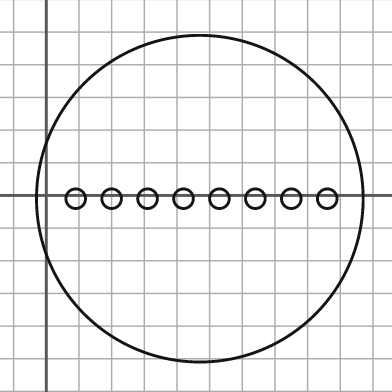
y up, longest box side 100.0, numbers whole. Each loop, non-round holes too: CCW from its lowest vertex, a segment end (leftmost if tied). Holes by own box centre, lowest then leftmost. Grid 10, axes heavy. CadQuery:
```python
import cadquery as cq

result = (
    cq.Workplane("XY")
    .moveTo(47.0, -1.0)
    .circle(50.0)
    .moveTo(9.0, -1.0)
    .circle(3.0)
    .moveTo(20.0, -1.0)
    .circle(3.0)
    .moveTo(31.0, -1.0)
    .circle(3.0)
    .moveTo(42.0, -1.0)
    .circle(3.0)
    .moveTo(53.0, -1.0)
    .circle(3.0)
    .moveTo(64.0, -1.0)
    .circle(3.0)
    .moveTo(75.0, -1.0)
    .circle(3.0)
    .moveTo(86.0, -1.0)
    .circle(3.0)
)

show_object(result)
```